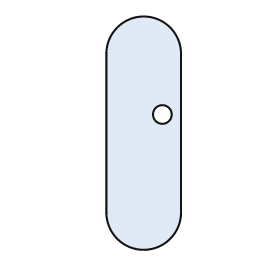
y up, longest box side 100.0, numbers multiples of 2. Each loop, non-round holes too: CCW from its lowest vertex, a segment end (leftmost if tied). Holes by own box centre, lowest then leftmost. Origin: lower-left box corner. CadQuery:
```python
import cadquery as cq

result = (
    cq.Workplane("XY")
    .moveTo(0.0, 16.0)
    .threePointArc((16.0, 0.0), (32.0, 16.0))
    .lineTo(32.0, 84.0)
    .threePointArc((16.0, 100.0), (0.0, 84.0))
    .close()
    .moveTo(24.0, 58.0)
    .circle(4.0)
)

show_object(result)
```